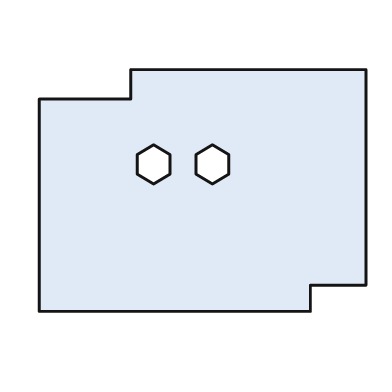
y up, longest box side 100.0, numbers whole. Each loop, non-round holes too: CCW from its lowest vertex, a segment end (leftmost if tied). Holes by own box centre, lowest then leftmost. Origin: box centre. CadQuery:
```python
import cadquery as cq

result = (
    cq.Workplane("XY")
    .moveTo(-50.0, -37.0)
    .lineTo(33.0, -37.0)
    .lineTo(33.0, -29.0)
    .lineTo(50.0, -29.0)
    .lineTo(50.0, 37.0)
    .lineTo(-22.0, 37.0)
    .lineTo(-22.0, 28.0)
    .lineTo(-50.0, 28.0)
    .close()
    .moveTo(-15.0, 2.0)
    .lineTo(-10.0, 5.0)
    .lineTo(-10.0, 11.0)
    .lineTo(-15.0, 14.0)
    .lineTo(-20.0, 11.0)
    .lineTo(-20.0, 5.0)
    .close()
    .moveTo(3.0, 2.0)
    .lineTo(8.0, 5.0)
    .lineTo(8.0, 11.0)
    .lineTo(3.0, 14.0)
    .lineTo(-2.0, 11.0)
    .lineTo(-2.0, 5.0)
    .close()
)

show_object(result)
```